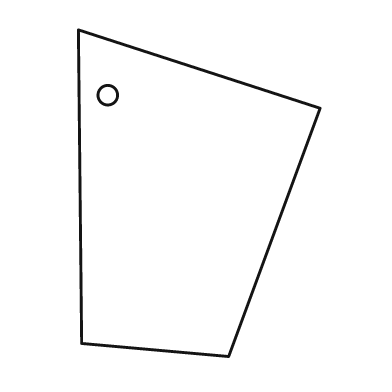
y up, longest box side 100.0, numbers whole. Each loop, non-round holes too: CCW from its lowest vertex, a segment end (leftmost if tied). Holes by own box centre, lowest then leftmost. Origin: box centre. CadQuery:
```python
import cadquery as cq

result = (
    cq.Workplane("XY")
    .moveTo(9.0, -50.0)
    .lineTo(37.0, 26.0)
    .lineTo(-37.0, 50.0)
    .lineTo(-36.0, -46.0)
    .close()
    .moveTo(-28.0, 30.0)
    .circle(3.0)
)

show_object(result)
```